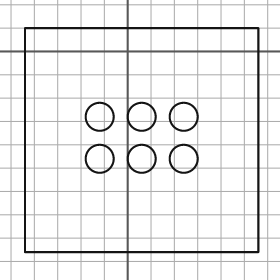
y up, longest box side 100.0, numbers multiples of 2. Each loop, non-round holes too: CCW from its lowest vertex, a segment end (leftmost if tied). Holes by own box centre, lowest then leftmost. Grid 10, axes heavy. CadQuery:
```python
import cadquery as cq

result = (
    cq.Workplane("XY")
    .moveTo(-44.0, -86.0)
    .lineTo(56.0, -86.0)
    .lineTo(56.0, 10.0)
    .lineTo(-44.0, 10.0)
    .close()
    .moveTo(-12.0, -46.0)
    .circle(6.0)
    .moveTo(6.0, -46.0)
    .circle(6.0)
    .moveTo(24.0, -46.0)
    .circle(6.0)
    .moveTo(-12.0, -28.0)
    .circle(6.0)
    .moveTo(6.0, -28.0)
    .circle(6.0)
    .moveTo(24.0, -28.0)
    .circle(6.0)
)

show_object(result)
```